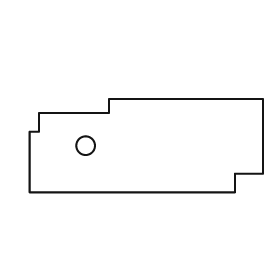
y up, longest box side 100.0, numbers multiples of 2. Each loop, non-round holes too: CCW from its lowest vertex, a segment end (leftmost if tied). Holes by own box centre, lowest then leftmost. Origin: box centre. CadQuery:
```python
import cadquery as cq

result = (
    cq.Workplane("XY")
    .moveTo(-50.0, -20.0)
    .lineTo(38.0, -20.0)
    .lineTo(38.0, -12.0)
    .lineTo(50.0, -12.0)
    .lineTo(50.0, 20.0)
    .lineTo(-16.0, 20.0)
    .lineTo(-16.0, 14.0)
    .lineTo(-46.0, 14.0)
    .lineTo(-46.0, 6.0)
    .lineTo(-50.0, 6.0)
    .close()
    .moveTo(-26.0, 0.0)
    .circle(4.0)
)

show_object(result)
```